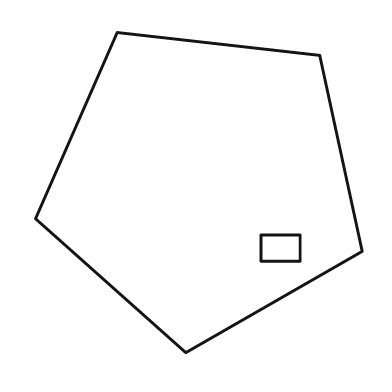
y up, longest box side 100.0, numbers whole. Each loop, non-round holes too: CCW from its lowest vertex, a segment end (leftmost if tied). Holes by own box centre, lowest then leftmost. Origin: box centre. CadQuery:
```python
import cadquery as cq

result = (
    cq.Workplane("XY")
    .moveTo(-4.0, -49.0)
    .lineTo(50.0, -18.0)
    .lineTo(37.0, 42.0)
    .lineTo(-25.0, 49.0)
    .lineTo(-50.0, -8.0)
    .close()
    .moveTo(19.0, -21.0)
    .lineTo(31.0, -21.0)
    .lineTo(31.0, -13.0)
    .lineTo(19.0, -13.0)
    .close()
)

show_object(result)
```